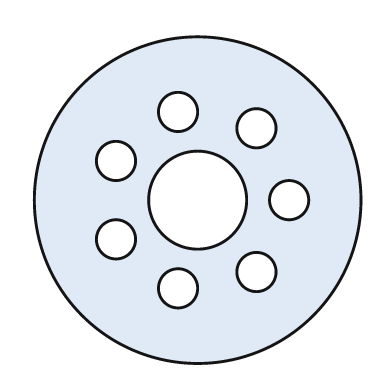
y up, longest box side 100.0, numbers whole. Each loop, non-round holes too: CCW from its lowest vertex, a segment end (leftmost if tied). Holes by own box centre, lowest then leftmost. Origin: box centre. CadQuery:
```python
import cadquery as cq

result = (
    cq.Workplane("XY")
    .moveTo(0.0, 0.0)
    .circle(50.0)
    .moveTo(-6.0, -27.0)
    .circle(6.0)
    .moveTo(18.0, -22.0)
    .circle(6.0)
    .moveTo(-25.0, -12.0)
    .circle(6.0)
    .moveTo(0.0, 0.0)
    .circle(15.0)
    .moveTo(28.0, 0.0)
    .circle(6.0)
    .moveTo(-25.0, 12.0)
    .circle(6.0)
    .moveTo(18.0, 22.0)
    .circle(6.0)
    .moveTo(-6.0, 27.0)
    .circle(6.0)
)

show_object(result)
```